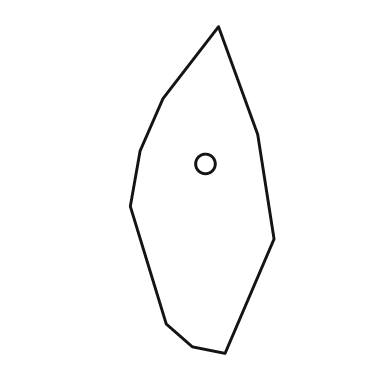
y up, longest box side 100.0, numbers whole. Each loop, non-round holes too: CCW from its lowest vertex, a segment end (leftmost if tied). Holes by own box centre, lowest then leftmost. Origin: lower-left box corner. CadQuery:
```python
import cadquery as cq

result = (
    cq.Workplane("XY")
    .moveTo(29.0, 0.0)
    .lineTo(44.0, 35.0)
    .lineTo(39.0, 67.0)
    .lineTo(27.0, 100.0)
    .lineTo(10.0, 78.0)
    .lineTo(3.0, 62.0)
    .lineTo(0.0, 45.0)
    .lineTo(11.0, 9.0)
    .lineTo(19.0, 2.0)
    .close()
    .moveTo(23.0, 58.0)
    .circle(3.0)
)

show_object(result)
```